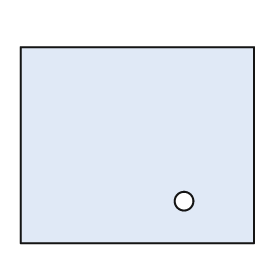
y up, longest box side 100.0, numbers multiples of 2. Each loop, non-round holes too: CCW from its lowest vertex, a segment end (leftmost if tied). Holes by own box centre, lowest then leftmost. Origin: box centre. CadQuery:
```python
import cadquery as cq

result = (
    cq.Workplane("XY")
    .moveTo(-50.0, -42.0)
    .lineTo(50.0, -42.0)
    .lineTo(50.0, 42.0)
    .lineTo(-50.0, 42.0)
    .close()
    .moveTo(20.0, -24.0)
    .circle(4.0)
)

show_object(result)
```